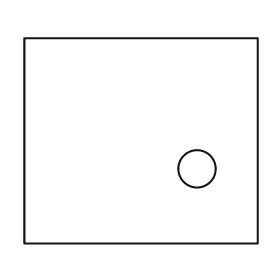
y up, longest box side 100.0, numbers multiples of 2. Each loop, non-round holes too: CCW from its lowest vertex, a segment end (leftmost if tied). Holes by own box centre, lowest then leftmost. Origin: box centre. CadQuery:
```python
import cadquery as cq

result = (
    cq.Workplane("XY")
    .moveTo(-50.0, -44.0)
    .lineTo(50.0, -44.0)
    .lineTo(50.0, 44.0)
    .lineTo(-50.0, 44.0)
    .close()
    .moveTo(24.0, -12.0)
    .circle(8.0)
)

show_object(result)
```